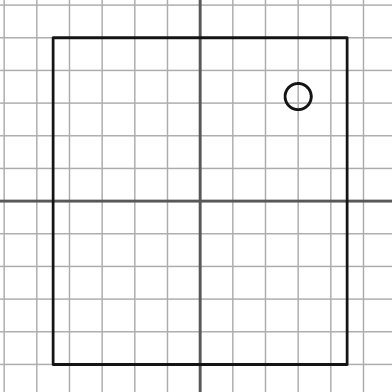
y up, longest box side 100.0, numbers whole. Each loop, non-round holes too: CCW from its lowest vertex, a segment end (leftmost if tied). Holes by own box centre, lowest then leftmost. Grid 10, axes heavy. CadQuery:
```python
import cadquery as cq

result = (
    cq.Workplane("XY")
    .moveTo(-45.0, -50.0)
    .lineTo(45.0, -50.0)
    .lineTo(45.0, 50.0)
    .lineTo(-45.0, 50.0)
    .close()
    .moveTo(30.0, 32.0)
    .circle(4.0)
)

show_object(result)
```